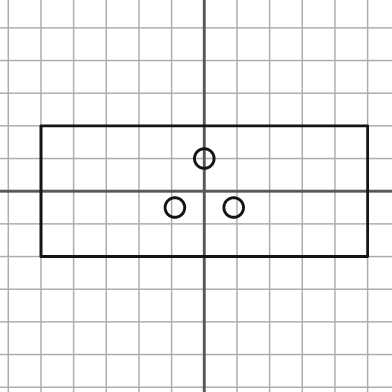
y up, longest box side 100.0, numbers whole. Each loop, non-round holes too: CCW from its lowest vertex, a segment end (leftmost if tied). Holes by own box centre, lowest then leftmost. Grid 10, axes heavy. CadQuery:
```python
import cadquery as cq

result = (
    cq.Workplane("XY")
    .moveTo(-50.0, -20.0)
    .lineTo(50.0, -20.0)
    .lineTo(50.0, 20.0)
    .lineTo(-50.0, 20.0)
    .close()
    .moveTo(-9.0, -5.0)
    .circle(3.0)
    .moveTo(9.0, -5.0)
    .circle(3.0)
    .moveTo(0.0, 10.0)
    .circle(3.0)
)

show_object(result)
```